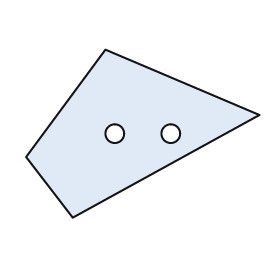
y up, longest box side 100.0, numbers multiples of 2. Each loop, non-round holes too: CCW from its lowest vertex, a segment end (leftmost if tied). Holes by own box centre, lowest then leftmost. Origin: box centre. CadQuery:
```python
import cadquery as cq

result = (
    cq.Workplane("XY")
    .moveTo(-30.0, -36.0)
    .lineTo(50.0, 8.0)
    .lineTo(-16.0, 36.0)
    .lineTo(-50.0, -10.0)
    .close()
    .moveTo(-12.0, 0.0)
    .circle(4.0)
    .moveTo(12.0, 0.0)
    .circle(4.0)
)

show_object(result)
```